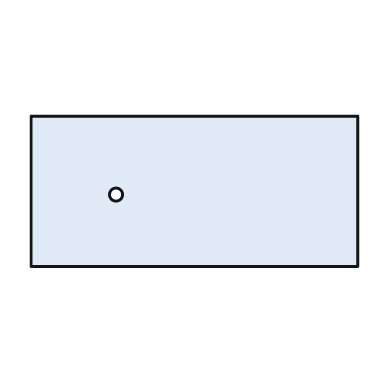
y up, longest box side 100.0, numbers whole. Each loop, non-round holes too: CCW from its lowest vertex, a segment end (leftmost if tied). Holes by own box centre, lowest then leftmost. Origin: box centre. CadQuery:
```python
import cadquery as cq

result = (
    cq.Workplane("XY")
    .moveTo(-50.0, -23.0)
    .lineTo(50.0, -23.0)
    .lineTo(50.0, 23.0)
    .lineTo(-50.0, 23.0)
    .close()
    .moveTo(-24.0, -1.0)
    .circle(2.0)
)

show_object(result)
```